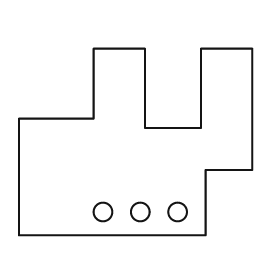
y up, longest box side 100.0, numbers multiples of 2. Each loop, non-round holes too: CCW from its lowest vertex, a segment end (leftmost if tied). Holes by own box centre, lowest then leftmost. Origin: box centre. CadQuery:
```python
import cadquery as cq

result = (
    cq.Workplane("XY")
    .moveTo(-50.0, -40.0)
    .lineTo(30.0, -40.0)
    .lineTo(30.0, -12.0)
    .lineTo(50.0, -12.0)
    .lineTo(50.0, 40.0)
    .lineTo(28.0, 40.0)
    .lineTo(28.0, 6.0)
    .lineTo(4.0, 6.0)
    .lineTo(4.0, 40.0)
    .lineTo(-18.0, 40.0)
    .lineTo(-18.0, 10.0)
    .lineTo(-50.0, 10.0)
    .close()
    .moveTo(-14.0, -30.0)
    .circle(4.0)
    .moveTo(2.0, -30.0)
    .circle(4.0)
    .moveTo(18.0, -30.0)
    .circle(4.0)
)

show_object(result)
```